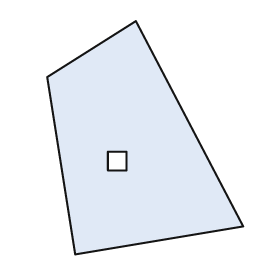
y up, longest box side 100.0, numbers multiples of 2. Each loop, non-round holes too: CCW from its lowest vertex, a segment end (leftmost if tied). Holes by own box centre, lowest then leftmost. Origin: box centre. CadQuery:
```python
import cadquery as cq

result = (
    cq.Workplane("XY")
    .moveTo(-30.0, -50.0)
    .lineTo(42.0, -38.0)
    .lineTo(-4.0, 50.0)
    .lineTo(-42.0, 26.0)
    .close()
    .moveTo(-16.0, -14.0)
    .lineTo(-8.0, -14.0)
    .lineTo(-8.0, -6.0)
    .lineTo(-16.0, -6.0)
    .close()
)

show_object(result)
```